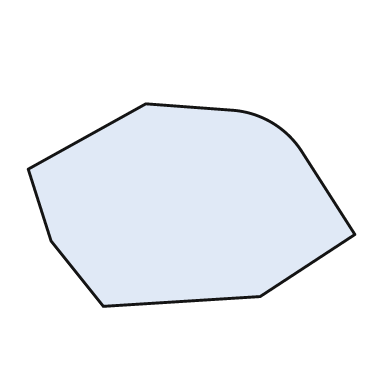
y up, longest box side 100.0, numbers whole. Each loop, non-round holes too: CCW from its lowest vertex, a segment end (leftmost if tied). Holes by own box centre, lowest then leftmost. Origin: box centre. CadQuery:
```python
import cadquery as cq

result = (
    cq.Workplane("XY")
    .moveTo(-27.0, -31.0)
    .lineTo(21.0, -28.0)
    .lineTo(50.0, -9.0)
    .lineTo(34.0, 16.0)
    .threePointArc((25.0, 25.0), (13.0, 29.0))
    .lineTo(-14.0, 31.0)
    .lineTo(-50.0, 11.0)
    .lineTo(-43.0, -11.0)
    .close()
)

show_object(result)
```